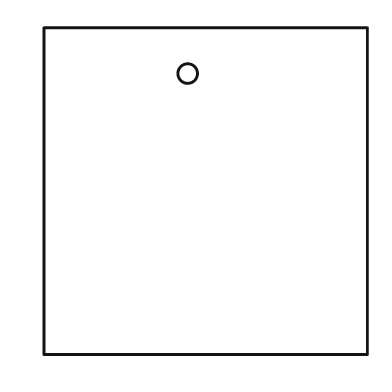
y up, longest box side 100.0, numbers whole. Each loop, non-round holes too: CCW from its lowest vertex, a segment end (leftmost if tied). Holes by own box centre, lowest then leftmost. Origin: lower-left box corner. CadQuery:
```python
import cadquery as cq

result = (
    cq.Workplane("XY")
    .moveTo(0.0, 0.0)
    .lineTo(99.0, 0.0)
    .lineTo(99.0, 100.0)
    .lineTo(0.0, 100.0)
    .close()
    .moveTo(44.0, 86.0)
    .circle(3.0)
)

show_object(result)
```